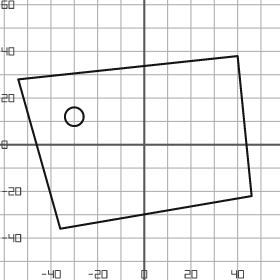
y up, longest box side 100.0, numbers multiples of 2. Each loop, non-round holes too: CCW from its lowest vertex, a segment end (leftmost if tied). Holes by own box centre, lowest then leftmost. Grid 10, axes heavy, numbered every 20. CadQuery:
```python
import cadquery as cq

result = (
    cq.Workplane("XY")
    .moveTo(-36.0, -36.0)
    .lineTo(46.0, -22.0)
    .lineTo(40.0, 38.0)
    .lineTo(-54.0, 28.0)
    .close()
    .moveTo(-30.0, 12.0)
    .circle(4.0)
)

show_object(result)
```